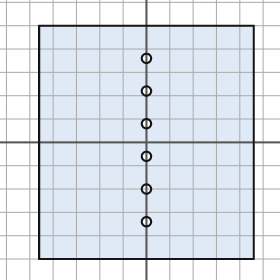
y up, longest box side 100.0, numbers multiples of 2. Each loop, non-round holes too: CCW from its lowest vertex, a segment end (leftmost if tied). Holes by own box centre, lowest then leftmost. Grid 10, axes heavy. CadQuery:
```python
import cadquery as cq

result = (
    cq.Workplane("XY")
    .moveTo(-46.0, -50.0)
    .lineTo(46.0, -50.0)
    .lineTo(46.0, 50.0)
    .lineTo(-46.0, 50.0)
    .close()
    .moveTo(0.0, -34.0)
    .circle(2.0)
    .moveTo(0.0, -20.0)
    .circle(2.0)
    .moveTo(0.0, -6.0)
    .circle(2.0)
    .moveTo(0.0, 8.0)
    .circle(2.0)
    .moveTo(0.0, 22.0)
    .circle(2.0)
    .moveTo(0.0, 36.0)
    .circle(2.0)
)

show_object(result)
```